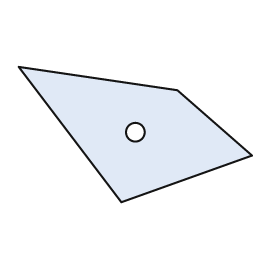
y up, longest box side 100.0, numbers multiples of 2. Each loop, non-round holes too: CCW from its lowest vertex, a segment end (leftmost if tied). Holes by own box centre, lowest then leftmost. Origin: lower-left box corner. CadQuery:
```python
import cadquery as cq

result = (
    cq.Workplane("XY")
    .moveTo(44.0, 0.0)
    .lineTo(100.0, 20.0)
    .lineTo(68.0, 48.0)
    .lineTo(0.0, 58.0)
    .close()
    .moveTo(50.0, 30.0)
    .circle(4.0)
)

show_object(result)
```